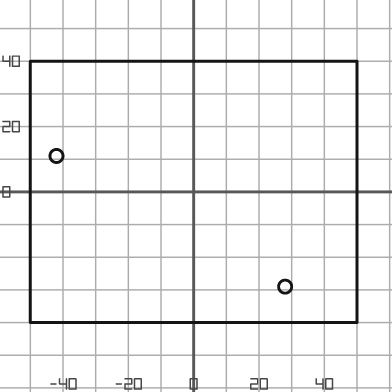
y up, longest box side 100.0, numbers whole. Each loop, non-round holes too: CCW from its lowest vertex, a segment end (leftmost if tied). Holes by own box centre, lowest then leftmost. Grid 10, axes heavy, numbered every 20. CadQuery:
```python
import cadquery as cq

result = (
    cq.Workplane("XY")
    .moveTo(-50.0, -40.0)
    .lineTo(50.0, -40.0)
    .lineTo(50.0, 40.0)
    .lineTo(-50.0, 40.0)
    .close()
    .moveTo(28.0, -29.0)
    .circle(2.0)
    .moveTo(-42.0, 11.0)
    .circle(2.0)
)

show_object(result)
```